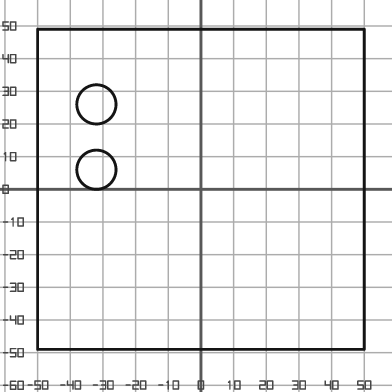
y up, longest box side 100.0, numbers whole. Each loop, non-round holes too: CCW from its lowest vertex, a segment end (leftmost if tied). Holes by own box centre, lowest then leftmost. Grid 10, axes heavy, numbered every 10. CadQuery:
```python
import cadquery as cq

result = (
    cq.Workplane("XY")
    .moveTo(-50.0, -49.0)
    .lineTo(50.0, -49.0)
    .lineTo(50.0, 49.0)
    .lineTo(-50.0, 49.0)
    .close()
    .moveTo(-32.0, 6.0)
    .circle(6.0)
    .moveTo(-32.0, 26.0)
    .circle(6.0)
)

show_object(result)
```